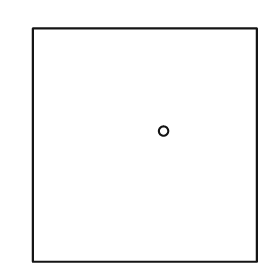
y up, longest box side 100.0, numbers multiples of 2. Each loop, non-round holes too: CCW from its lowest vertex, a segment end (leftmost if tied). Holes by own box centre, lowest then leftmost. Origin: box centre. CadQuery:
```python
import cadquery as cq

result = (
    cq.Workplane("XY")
    .moveTo(-48.0, -50.0)
    .lineTo(48.0, -50.0)
    .lineTo(48.0, 50.0)
    .lineTo(-48.0, 50.0)
    .close()
    .moveTo(8.0, 6.0)
    .circle(2.0)
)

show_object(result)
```